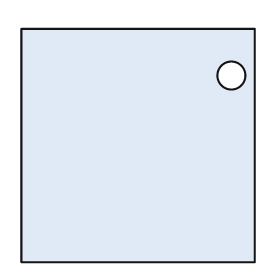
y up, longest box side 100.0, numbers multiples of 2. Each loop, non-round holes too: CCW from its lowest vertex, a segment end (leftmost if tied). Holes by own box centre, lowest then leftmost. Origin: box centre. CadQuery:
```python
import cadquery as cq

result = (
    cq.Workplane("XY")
    .moveTo(-50.0, -50.0)
    .lineTo(50.0, -50.0)
    .lineTo(50.0, 50.0)
    .lineTo(-50.0, 50.0)
    .close()
    .moveTo(40.0, 30.0)
    .circle(6.0)
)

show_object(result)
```